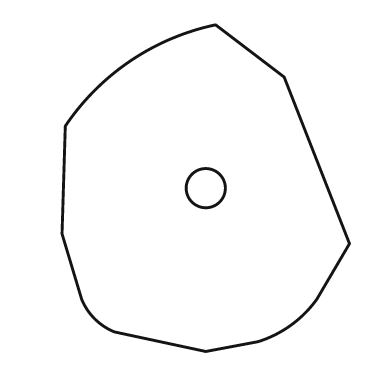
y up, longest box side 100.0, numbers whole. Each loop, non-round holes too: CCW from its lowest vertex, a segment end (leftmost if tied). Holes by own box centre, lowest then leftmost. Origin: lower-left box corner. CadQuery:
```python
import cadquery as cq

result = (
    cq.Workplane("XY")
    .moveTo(44.0, 0.0)
    .lineTo(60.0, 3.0)
    .threePointArc((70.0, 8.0), (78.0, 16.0))
    .lineTo(88.0, 33.0)
    .lineTo(68.0, 84.0)
    .lineTo(47.0, 100.0)
    .threePointArc((21.0, 89.0), (1.0, 69.0))
    .lineTo(0.0, 36.0)
    .lineTo(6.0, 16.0)
    .threePointArc((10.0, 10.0), (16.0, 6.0))
    .close()
    .moveTo(44.0, 50.0)
    .circle(6.0)
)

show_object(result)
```